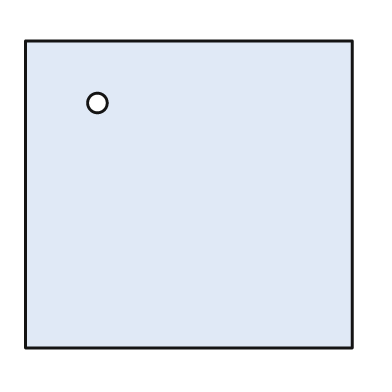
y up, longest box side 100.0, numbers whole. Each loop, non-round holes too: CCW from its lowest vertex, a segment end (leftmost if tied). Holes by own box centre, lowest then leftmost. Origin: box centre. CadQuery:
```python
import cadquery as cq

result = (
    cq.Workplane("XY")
    .moveTo(-50.0, -47.0)
    .lineTo(50.0, -47.0)
    .lineTo(50.0, 47.0)
    .lineTo(-50.0, 47.0)
    .close()
    .moveTo(-28.0, 28.0)
    .circle(3.0)
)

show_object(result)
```